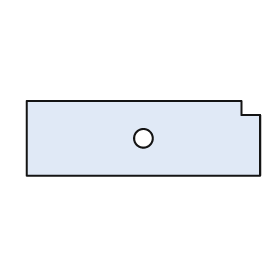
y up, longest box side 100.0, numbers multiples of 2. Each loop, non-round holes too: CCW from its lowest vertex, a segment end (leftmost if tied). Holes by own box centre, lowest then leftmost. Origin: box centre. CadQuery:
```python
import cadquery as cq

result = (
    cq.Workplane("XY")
    .moveTo(-50.0, -16.0)
    .lineTo(50.0, -16.0)
    .lineTo(50.0, 10.0)
    .lineTo(42.0, 10.0)
    .lineTo(42.0, 16.0)
    .lineTo(-50.0, 16.0)
    .close()
    .moveTo(0.0, 0.0)
    .circle(4.0)
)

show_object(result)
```